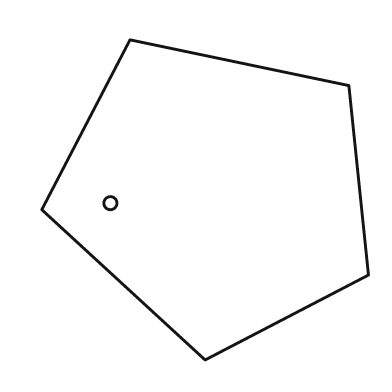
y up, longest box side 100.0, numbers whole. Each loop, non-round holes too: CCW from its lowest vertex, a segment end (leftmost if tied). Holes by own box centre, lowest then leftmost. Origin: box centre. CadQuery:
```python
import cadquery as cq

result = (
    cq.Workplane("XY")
    .moveTo(0.0, -49.0)
    .lineTo(50.0, -23.0)
    .lineTo(44.0, 35.0)
    .lineTo(-23.0, 49.0)
    .lineTo(-50.0, -3.0)
    .close()
    .moveTo(-29.0, -1.0)
    .circle(2.0)
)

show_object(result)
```